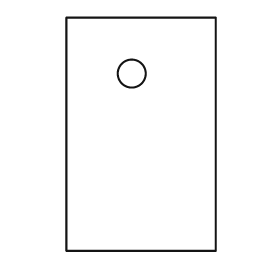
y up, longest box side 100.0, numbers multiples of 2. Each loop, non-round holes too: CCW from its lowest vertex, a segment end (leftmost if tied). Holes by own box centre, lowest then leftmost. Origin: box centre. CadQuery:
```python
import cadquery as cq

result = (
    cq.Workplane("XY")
    .moveTo(-32.0, -50.0)
    .lineTo(32.0, -50.0)
    .lineTo(32.0, 50.0)
    .lineTo(-32.0, 50.0)
    .close()
    .moveTo(-4.0, 26.0)
    .circle(6.0)
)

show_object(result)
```